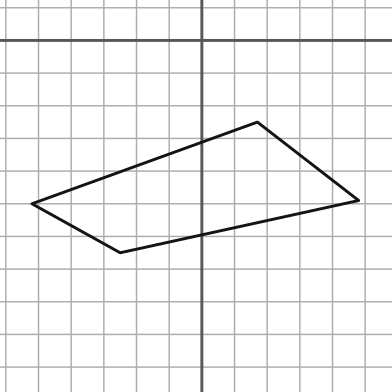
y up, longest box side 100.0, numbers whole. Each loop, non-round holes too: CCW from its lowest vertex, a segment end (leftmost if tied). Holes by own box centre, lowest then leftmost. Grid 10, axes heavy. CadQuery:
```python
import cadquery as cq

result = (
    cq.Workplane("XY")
    .moveTo(-25.0, -65.0)
    .lineTo(48.0, -49.0)
    .lineTo(17.0, -25.0)
    .lineTo(-52.0, -50.0)
    .close()
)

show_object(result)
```